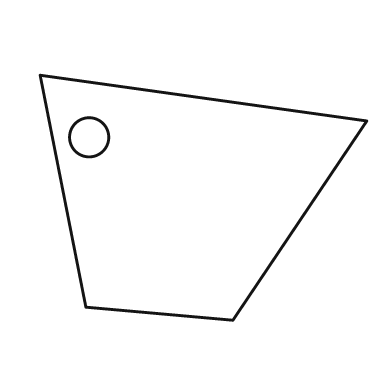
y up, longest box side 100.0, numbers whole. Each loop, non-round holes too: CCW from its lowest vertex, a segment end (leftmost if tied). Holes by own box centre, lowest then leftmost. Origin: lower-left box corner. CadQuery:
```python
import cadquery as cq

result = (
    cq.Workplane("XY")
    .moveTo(59.0, 0.0)
    .lineTo(100.0, 61.0)
    .lineTo(0.0, 75.0)
    .lineTo(14.0, 4.0)
    .close()
    .moveTo(15.0, 56.0)
    .circle(6.0)
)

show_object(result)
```